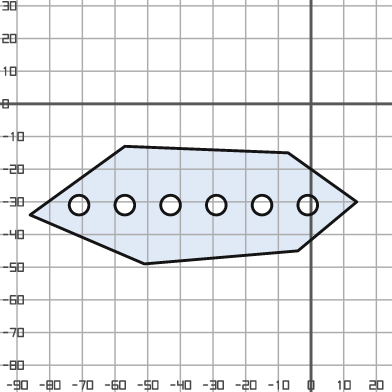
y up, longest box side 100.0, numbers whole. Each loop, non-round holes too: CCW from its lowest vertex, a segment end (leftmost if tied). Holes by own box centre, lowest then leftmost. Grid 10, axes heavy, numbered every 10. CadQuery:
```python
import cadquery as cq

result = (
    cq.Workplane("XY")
    .moveTo(-51.0, -49.0)
    .lineTo(-4.0, -45.0)
    .lineTo(14.0, -30.0)
    .lineTo(-7.0, -15.0)
    .lineTo(-57.0, -13.0)
    .lineTo(-86.0, -34.0)
    .close()
    .moveTo(-71.0, -31.0)
    .circle(3.0)
    .moveTo(-57.0, -31.0)
    .circle(3.0)
    .moveTo(-43.0, -31.0)
    .circle(3.0)
    .moveTo(-29.0, -31.0)
    .circle(3.0)
    .moveTo(-15.0, -31.0)
    .circle(3.0)
    .moveTo(-1.0, -31.0)
    .circle(3.0)
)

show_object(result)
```